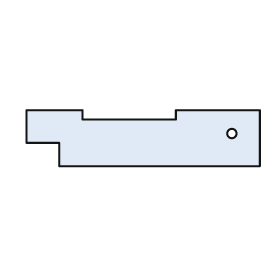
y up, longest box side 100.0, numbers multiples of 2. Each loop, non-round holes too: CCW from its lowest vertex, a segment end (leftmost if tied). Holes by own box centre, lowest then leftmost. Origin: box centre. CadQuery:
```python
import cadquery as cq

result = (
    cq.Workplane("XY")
    .moveTo(-36.0, -12.0)
    .lineTo(50.0, -12.0)
    .lineTo(50.0, 12.0)
    .lineTo(14.0, 12.0)
    .lineTo(14.0, 8.0)
    .lineTo(-26.0, 8.0)
    .lineTo(-26.0, 12.0)
    .lineTo(-50.0, 12.0)
    .lineTo(-50.0, -2.0)
    .lineTo(-36.0, -2.0)
    .close()
    .moveTo(38.0, 2.0)
    .circle(2.0)
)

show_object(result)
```